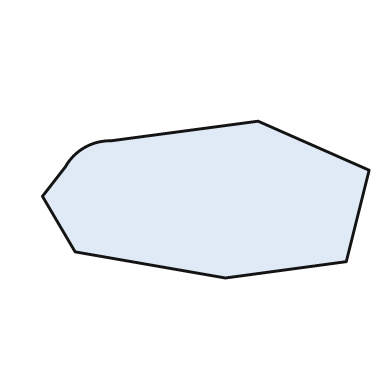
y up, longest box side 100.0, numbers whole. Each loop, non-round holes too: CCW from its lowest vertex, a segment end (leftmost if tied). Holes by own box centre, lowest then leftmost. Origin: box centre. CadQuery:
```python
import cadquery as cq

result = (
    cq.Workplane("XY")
    .moveTo(6.0, -24.0)
    .lineTo(43.0, -19.0)
    .lineTo(50.0, 9.0)
    .lineTo(16.0, 24.0)
    .lineTo(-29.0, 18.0)
    .threePointArc((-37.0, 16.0), (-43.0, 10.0))
    .lineTo(-50.0, 1.0)
    .lineTo(-40.0, -16.0)
    .close()
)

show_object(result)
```